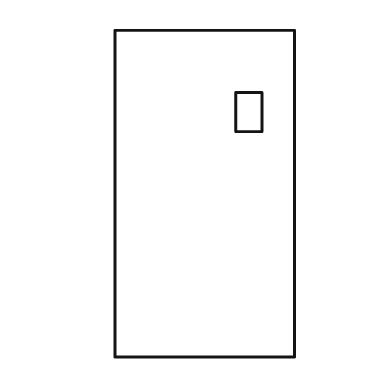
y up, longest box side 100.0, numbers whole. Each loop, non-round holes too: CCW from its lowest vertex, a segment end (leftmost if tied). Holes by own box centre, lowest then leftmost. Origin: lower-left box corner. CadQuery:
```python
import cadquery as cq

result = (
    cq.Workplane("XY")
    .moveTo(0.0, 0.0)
    .lineTo(55.0, 0.0)
    .lineTo(55.0, 100.0)
    .lineTo(0.0, 100.0)
    .close()
    .moveTo(37.0, 69.0)
    .lineTo(45.0, 69.0)
    .lineTo(45.0, 81.0)
    .lineTo(37.0, 81.0)
    .close()
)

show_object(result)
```